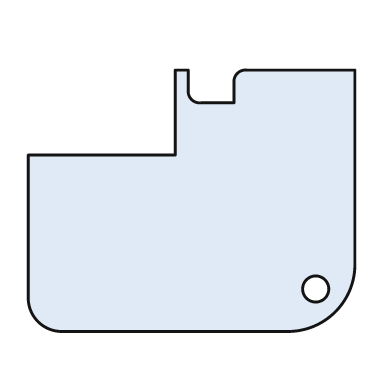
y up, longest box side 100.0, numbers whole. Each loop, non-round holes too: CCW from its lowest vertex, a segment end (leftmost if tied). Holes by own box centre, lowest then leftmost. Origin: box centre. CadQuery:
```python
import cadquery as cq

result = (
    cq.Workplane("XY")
    .moveTo(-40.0, -40.0)
    .lineTo(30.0, -40.0)
    .threePointArc((44.0, -34.0), (50.0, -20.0))
    .lineTo(50.0, 40.0)
    .lineTo(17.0, 40.0)
    .threePointArc((14.0, 39.0), (13.0, 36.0))
    .lineTo(13.0, 30.0)
    .lineTo(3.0, 30.0)
    .threePointArc((0.0, 31.0), (-1.0, 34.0))
    .lineTo(-1.0, 40.0)
    .lineTo(-5.0, 40.0)
    .lineTo(-5.0, 14.0)
    .lineTo(-50.0, 14.0)
    .lineTo(-50.0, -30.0)
    .threePointArc((-47.0, -37.0), (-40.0, -40.0))
    .close()
    .moveTo(38.0, -27.0)
    .circle(4.0)
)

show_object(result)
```